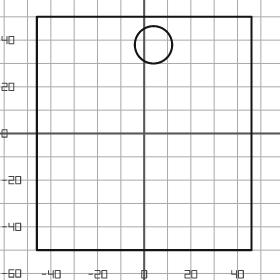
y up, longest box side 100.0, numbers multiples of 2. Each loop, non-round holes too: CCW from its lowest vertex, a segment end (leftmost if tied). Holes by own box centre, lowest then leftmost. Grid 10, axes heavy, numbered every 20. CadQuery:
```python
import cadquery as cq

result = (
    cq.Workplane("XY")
    .moveTo(-46.0, -50.0)
    .lineTo(46.0, -50.0)
    .lineTo(46.0, 50.0)
    .lineTo(-46.0, 50.0)
    .close()
    .moveTo(4.0, 38.0)
    .circle(8.0)
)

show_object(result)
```